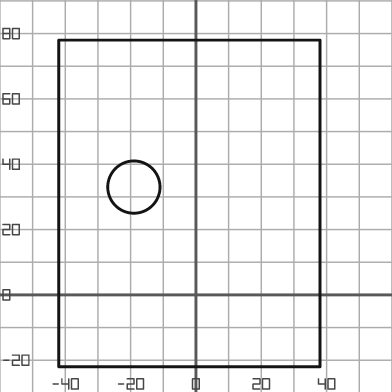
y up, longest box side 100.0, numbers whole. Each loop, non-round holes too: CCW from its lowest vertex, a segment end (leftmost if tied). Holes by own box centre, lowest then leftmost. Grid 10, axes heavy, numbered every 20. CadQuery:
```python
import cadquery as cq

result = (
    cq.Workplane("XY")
    .moveTo(-42.0, -22.0)
    .lineTo(38.0, -22.0)
    .lineTo(38.0, 78.0)
    .lineTo(-42.0, 78.0)
    .close()
    .moveTo(-19.0, 33.0)
    .circle(8.0)
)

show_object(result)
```